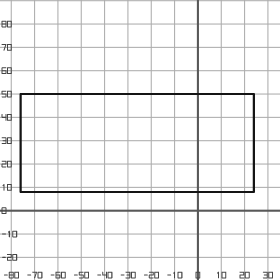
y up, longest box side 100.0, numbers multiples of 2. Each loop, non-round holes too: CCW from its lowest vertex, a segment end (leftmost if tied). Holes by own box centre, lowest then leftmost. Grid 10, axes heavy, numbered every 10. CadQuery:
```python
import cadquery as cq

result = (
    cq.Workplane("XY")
    .moveTo(-76.0, 8.0)
    .lineTo(24.0, 8.0)
    .lineTo(24.0, 50.0)
    .lineTo(-76.0, 50.0)
    .close()
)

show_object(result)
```